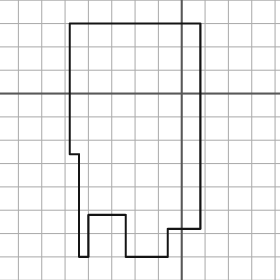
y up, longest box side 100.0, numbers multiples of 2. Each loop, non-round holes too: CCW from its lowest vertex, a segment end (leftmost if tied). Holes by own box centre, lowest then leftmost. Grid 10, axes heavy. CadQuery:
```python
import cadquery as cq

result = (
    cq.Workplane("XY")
    .moveTo(-44.0, -70.0)
    .lineTo(-40.0, -70.0)
    .lineTo(-40.0, -52.0)
    .lineTo(-24.0, -52.0)
    .lineTo(-24.0, -70.0)
    .lineTo(-6.0, -70.0)
    .lineTo(-6.0, -58.0)
    .lineTo(8.0, -58.0)
    .lineTo(8.0, 30.0)
    .lineTo(-48.0, 30.0)
    .lineTo(-48.0, -26.0)
    .lineTo(-44.0, -26.0)
    .close()
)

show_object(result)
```